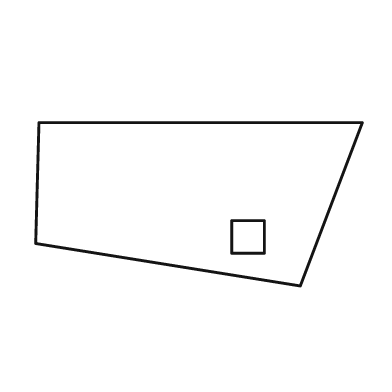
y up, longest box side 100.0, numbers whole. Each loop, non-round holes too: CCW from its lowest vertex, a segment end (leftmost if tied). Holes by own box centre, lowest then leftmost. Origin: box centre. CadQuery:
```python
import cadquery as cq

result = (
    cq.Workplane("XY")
    .moveTo(31.0, -25.0)
    .lineTo(50.0, 25.0)
    .lineTo(-49.0, 25.0)
    .lineTo(-50.0, -12.0)
    .close()
    .moveTo(10.0, -15.0)
    .lineTo(20.0, -15.0)
    .lineTo(20.0, -5.0)
    .lineTo(10.0, -5.0)
    .close()
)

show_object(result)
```